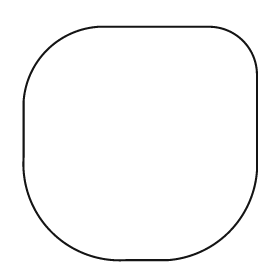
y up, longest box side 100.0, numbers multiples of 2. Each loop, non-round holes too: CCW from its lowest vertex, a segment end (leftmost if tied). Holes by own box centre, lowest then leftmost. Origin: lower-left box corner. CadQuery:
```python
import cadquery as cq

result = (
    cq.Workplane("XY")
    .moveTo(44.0, 0.0)
    .lineTo(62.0, 0.0)
    .threePointArc((88.0, 12.0), (100.0, 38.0))
    .lineTo(100.0, 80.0)
    .threePointArc((94.0, 94.0), (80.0, 100.0))
    .lineTo(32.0, 100.0)
    .threePointArc((10.0, 90.0), (0.0, 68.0))
    .lineTo(0.0, 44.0)
    .threePointArc((12.0, 12.0), (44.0, 0.0))
    .close()
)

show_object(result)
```